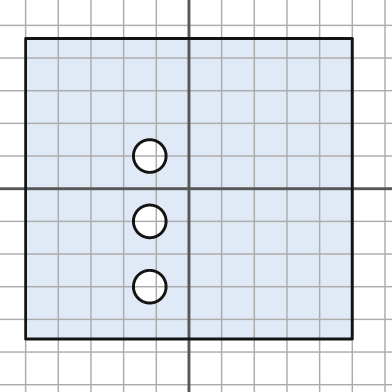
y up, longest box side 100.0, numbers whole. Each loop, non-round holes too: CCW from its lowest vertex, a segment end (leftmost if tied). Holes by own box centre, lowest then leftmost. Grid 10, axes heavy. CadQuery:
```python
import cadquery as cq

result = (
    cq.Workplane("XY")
    .moveTo(-50.0, -46.0)
    .lineTo(50.0, -46.0)
    .lineTo(50.0, 46.0)
    .lineTo(-50.0, 46.0)
    .close()
    .moveTo(-12.0, -30.0)
    .circle(5.0)
    .moveTo(-12.0, -10.0)
    .circle(5.0)
    .moveTo(-12.0, 10.0)
    .circle(5.0)
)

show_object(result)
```